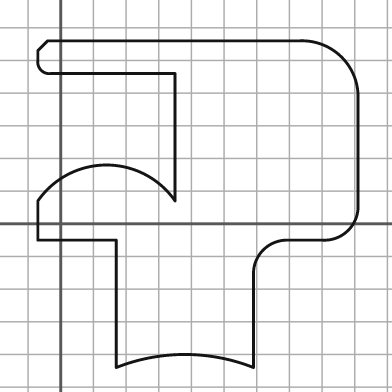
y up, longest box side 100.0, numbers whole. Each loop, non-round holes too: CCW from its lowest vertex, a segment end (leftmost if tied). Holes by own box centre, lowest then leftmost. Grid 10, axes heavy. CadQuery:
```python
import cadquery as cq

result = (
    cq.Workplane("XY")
    .moveTo(17.0, -44.0)
    .threePointArc((38.0, -40.0), (59.0, -44.0))
    .lineTo(59.0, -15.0)
    .threePointArc((62.0, -8.0), (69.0, -5.0))
    .lineTo(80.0, -5.0)
    .threePointArc((88.0, -2.0), (91.0, 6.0))
    .lineTo(91.0, 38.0)
    .threePointArc((86.0, 51.0), (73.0, 56.0))
    .lineTo(-4.0, 56.0)
    .lineTo(-7.0, 53.0)
    .lineTo(-7.0, 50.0)
    .threePointArc((-6.0, 47.0), (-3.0, 46.0))
    .lineTo(35.0, 46.0)
    .lineTo(35.0, 7.0)
    .threePointArc((14.0, 18.0), (-7.0, 7.0))
    .lineTo(-7.0, -5.0)
    .lineTo(17.0, -5.0)
    .close()
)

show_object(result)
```